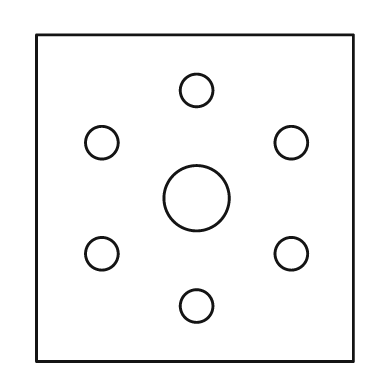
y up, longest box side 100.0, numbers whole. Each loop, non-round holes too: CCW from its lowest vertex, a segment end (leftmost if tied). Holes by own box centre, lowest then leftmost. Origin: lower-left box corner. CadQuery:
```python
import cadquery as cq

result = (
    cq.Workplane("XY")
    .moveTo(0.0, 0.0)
    .lineTo(97.0, 0.0)
    .lineTo(97.0, 100.0)
    .lineTo(0.0, 100.0)
    .close()
    .moveTo(49.0, 17.0)
    .circle(5.0)
    .moveTo(20.0, 33.0)
    .circle(5.0)
    .moveTo(78.0, 33.0)
    .circle(5.0)
    .moveTo(49.0, 50.0)
    .circle(10.0)
    .moveTo(20.0, 67.0)
    .circle(5.0)
    .moveTo(78.0, 67.0)
    .circle(5.0)
    .moveTo(49.0, 83.0)
    .circle(5.0)
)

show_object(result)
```